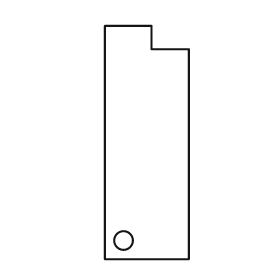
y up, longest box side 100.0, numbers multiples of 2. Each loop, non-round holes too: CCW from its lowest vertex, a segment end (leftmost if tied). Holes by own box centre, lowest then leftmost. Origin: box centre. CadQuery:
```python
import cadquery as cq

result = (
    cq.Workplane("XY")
    .moveTo(-18.0, -50.0)
    .lineTo(18.0, -50.0)
    .lineTo(18.0, 40.0)
    .lineTo(2.0, 40.0)
    .lineTo(2.0, 50.0)
    .lineTo(-18.0, 50.0)
    .close()
    .moveTo(-10.0, -42.0)
    .circle(4.0)
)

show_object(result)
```